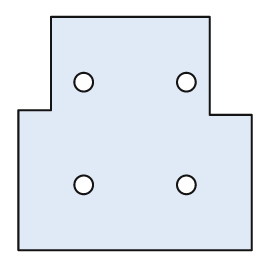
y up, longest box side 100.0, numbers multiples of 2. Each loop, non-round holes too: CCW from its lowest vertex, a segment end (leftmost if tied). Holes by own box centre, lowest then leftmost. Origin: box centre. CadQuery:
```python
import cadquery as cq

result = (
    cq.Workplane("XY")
    .moveTo(-50.0, -50.0)
    .lineTo(50.0, -50.0)
    .lineTo(50.0, 8.0)
    .lineTo(32.0, 8.0)
    .lineTo(32.0, 50.0)
    .lineTo(-36.0, 50.0)
    .lineTo(-36.0, 10.0)
    .lineTo(-50.0, 10.0)
    .close()
    .moveTo(-22.0, -22.0)
    .circle(4.0)
    .moveTo(22.0, -22.0)
    .circle(4.0)
    .moveTo(-22.0, 22.0)
    .circle(4.0)
    .moveTo(22.0, 22.0)
    .circle(4.0)
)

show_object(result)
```